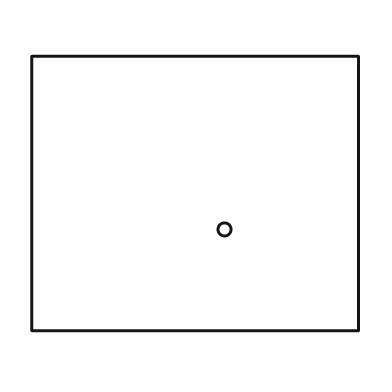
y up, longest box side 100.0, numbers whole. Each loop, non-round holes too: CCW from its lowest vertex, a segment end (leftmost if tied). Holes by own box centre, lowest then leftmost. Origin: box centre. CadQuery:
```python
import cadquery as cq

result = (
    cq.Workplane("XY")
    .moveTo(-50.0, -42.0)
    .lineTo(50.0, -42.0)
    .lineTo(50.0, 42.0)
    .lineTo(-50.0, 42.0)
    .close()
    .moveTo(9.0, -11.0)
    .circle(2.0)
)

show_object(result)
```